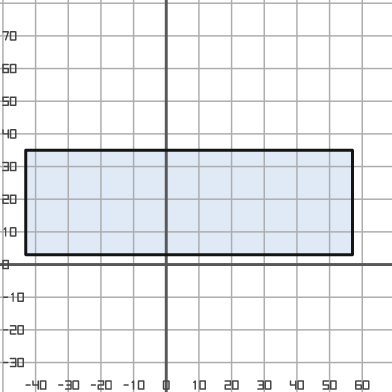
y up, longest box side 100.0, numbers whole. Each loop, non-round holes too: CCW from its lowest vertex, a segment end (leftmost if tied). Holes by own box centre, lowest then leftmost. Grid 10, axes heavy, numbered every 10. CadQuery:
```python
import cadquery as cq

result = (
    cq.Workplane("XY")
    .moveTo(-43.0, 3.0)
    .lineTo(57.0, 3.0)
    .lineTo(57.0, 35.0)
    .lineTo(-43.0, 35.0)
    .close()
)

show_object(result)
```